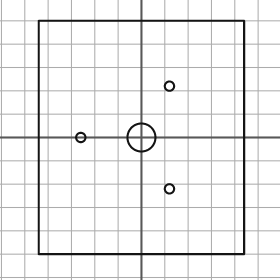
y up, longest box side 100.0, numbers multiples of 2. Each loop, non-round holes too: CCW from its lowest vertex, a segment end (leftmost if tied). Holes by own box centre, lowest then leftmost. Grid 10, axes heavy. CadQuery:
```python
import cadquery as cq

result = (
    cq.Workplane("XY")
    .moveTo(-44.0, -50.0)
    .lineTo(44.0, -50.0)
    .lineTo(44.0, 50.0)
    .lineTo(-44.0, 50.0)
    .close()
    .moveTo(12.0, -22.0)
    .circle(2.0)
    .moveTo(-26.0, 0.0)
    .circle(2.0)
    .moveTo(0.0, 0.0)
    .circle(6.0)
    .moveTo(12.0, 22.0)
    .circle(2.0)
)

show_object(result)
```